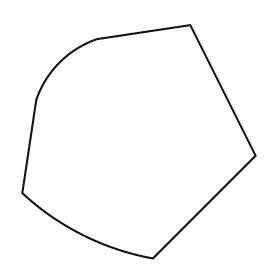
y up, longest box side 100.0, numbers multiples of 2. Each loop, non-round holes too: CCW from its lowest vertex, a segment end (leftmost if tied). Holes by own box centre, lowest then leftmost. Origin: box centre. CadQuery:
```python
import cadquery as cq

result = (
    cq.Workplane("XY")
    .moveTo(6.0, -50.0)
    .lineTo(50.0, -6.0)
    .lineTo(22.0, 50.0)
    .lineTo(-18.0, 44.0)
    .threePointArc((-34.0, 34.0), (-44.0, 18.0))
    .lineTo(-50.0, -22.0)
    .threePointArc((-24.0, -40.0), (6.0, -50.0))
    .close()
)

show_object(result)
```